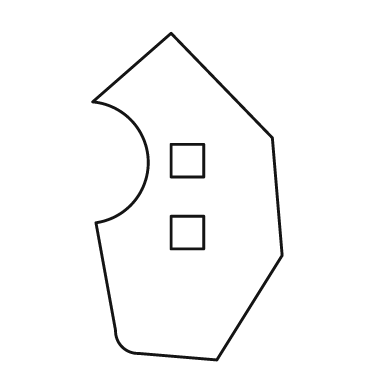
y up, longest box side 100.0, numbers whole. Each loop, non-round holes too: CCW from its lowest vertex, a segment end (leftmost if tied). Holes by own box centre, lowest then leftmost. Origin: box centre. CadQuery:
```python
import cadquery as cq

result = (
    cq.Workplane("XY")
    .moveTo(9.0, -50.0)
    .lineTo(29.0, -18.0)
    .lineTo(26.0, 18.0)
    .lineTo(-5.0, 50.0)
    .lineTo(-29.0, 29.0)
    .threePointArc((-12.0, 11.0), (-28.0, -8.0))
    .lineTo(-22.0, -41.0)
    .threePointArc((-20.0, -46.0), (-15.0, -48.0))
    .close()
    .moveTo(-5.0, -16.0)
    .lineTo(5.0, -16.0)
    .lineTo(5.0, -6.0)
    .lineTo(-5.0, -6.0)
    .close()
    .moveTo(-5.0, 6.0)
    .lineTo(5.0, 6.0)
    .lineTo(5.0, 16.0)
    .lineTo(-5.0, 16.0)
    .close()
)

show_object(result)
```